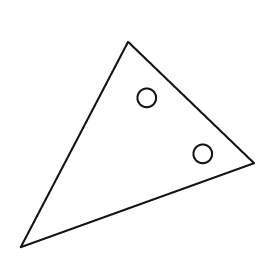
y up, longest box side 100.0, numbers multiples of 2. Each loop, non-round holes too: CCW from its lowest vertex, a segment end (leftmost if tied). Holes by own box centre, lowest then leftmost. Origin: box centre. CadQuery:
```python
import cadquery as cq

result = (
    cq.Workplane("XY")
    .moveTo(-50.0, -44.0)
    .lineTo(50.0, -8.0)
    .lineTo(-4.0, 44.0)
    .close()
    .moveTo(28.0, -4.0)
    .circle(4.0)
    .moveTo(4.0, 20.0)
    .circle(4.0)
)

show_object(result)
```